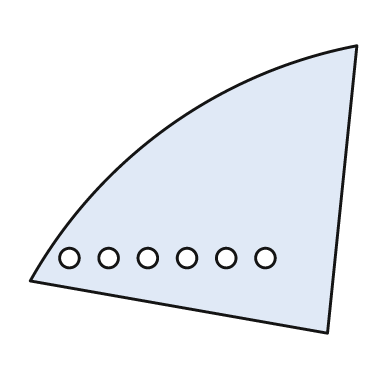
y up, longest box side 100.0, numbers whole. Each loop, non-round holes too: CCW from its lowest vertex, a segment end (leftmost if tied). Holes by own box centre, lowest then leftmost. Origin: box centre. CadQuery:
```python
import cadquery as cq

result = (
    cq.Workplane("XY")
    .moveTo(41.0, -44.0)
    .lineTo(50.0, 44.0)
    .threePointArc((-8.0, 19.0), (-50.0, -28.0))
    .close()
    .moveTo(-38.0, -21.0)
    .circle(3.0)
    .moveTo(-26.0, -21.0)
    .circle(3.0)
    .moveTo(-14.0, -21.0)
    .circle(3.0)
    .moveTo(-2.0, -21.0)
    .circle(3.0)
    .moveTo(10.0, -21.0)
    .circle(3.0)
    .moveTo(22.0, -21.0)
    .circle(3.0)
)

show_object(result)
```